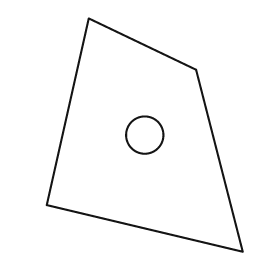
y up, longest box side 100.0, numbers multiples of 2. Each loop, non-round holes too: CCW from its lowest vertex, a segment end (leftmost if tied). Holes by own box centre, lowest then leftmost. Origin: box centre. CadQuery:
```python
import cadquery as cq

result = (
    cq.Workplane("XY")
    .moveTo(42.0, -50.0)
    .lineTo(22.0, 28.0)
    .lineTo(-24.0, 50.0)
    .lineTo(-42.0, -30.0)
    .close()
    .moveTo(0.0, 0.0)
    .circle(8.0)
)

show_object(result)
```